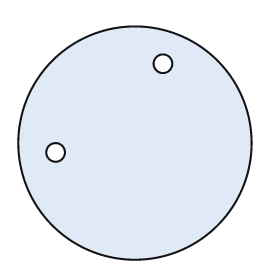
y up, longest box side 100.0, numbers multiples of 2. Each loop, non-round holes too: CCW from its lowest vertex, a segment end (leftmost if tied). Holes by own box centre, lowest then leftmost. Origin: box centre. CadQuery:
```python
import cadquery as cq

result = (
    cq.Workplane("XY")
    .moveTo(0.0, 0.0)
    .circle(50.0)
    .moveTo(-34.0, -4.0)
    .circle(4.0)
    .moveTo(12.0, 34.0)
    .circle(4.0)
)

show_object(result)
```